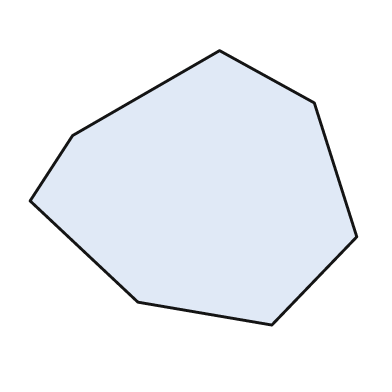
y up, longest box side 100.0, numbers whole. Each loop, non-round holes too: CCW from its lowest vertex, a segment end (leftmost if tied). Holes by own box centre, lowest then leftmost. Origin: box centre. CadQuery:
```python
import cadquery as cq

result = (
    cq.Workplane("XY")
    .moveTo(24.0, -42.0)
    .lineTo(50.0, -15.0)
    .lineTo(37.0, 26.0)
    .lineTo(8.0, 42.0)
    .lineTo(-37.0, 16.0)
    .lineTo(-50.0, -4.0)
    .lineTo(-17.0, -35.0)
    .close()
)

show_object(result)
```